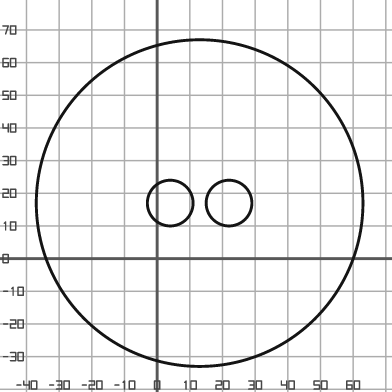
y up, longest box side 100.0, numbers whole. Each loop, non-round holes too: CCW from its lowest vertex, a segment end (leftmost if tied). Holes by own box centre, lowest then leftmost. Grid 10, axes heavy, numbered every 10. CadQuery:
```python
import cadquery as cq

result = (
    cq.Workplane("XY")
    .moveTo(13.0, 17.0)
    .circle(50.0)
    .moveTo(4.0, 17.0)
    .circle(7.0)
    .moveTo(22.0, 17.0)
    .circle(7.0)
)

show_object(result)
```